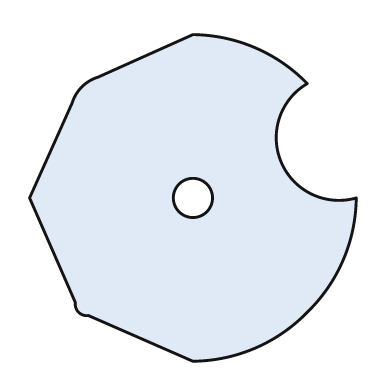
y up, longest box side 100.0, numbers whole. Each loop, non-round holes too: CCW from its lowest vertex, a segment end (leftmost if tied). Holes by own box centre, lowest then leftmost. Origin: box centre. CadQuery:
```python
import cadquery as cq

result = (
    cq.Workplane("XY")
    .moveTo(0.0, -50.0)
    .threePointArc((19.0, -46.0), (35.0, -35.0))
    .threePointArc((46.0, -19.0), (50.0, 0.0))
    .threePointArc((27.0, 11.0), (35.0, 35.0))
    .threePointArc((19.0, 46.0), (0.0, 50.0))
    .lineTo(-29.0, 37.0)
    .threePointArc((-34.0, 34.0), (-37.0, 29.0))
    .lineTo(-50.0, 0.0)
    .lineTo(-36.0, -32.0)
    .threePointArc((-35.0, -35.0), (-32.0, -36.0))
    .close()
    .moveTo(0.0, 0.0)
    .circle(6.0)
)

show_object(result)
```